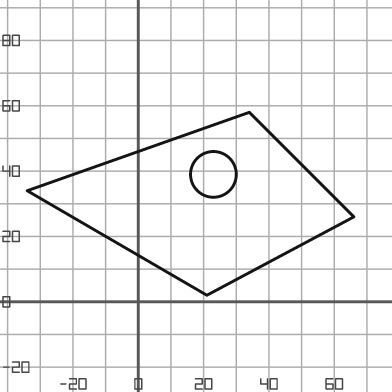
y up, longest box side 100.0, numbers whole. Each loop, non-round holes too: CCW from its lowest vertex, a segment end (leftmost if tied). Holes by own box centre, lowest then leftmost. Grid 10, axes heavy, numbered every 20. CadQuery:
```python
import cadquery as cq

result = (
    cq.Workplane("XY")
    .moveTo(21.0, 2.0)
    .lineTo(66.0, 26.0)
    .lineTo(34.0, 58.0)
    .lineTo(-34.0, 34.0)
    .close()
    .moveTo(23.0, 39.0)
    .circle(7.0)
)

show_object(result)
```